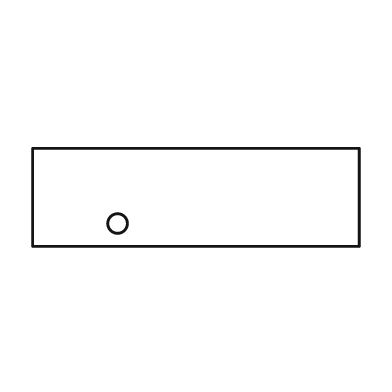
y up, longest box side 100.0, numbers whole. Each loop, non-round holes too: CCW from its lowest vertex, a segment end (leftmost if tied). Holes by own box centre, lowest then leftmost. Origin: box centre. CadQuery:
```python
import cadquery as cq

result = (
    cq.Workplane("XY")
    .moveTo(-50.0, -15.0)
    .lineTo(50.0, -15.0)
    .lineTo(50.0, 15.0)
    .lineTo(-50.0, 15.0)
    .close()
    .moveTo(-24.0, -8.0)
    .circle(3.0)
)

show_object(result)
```